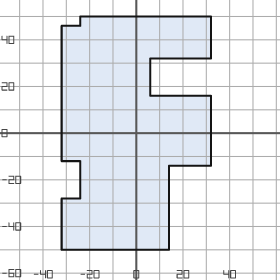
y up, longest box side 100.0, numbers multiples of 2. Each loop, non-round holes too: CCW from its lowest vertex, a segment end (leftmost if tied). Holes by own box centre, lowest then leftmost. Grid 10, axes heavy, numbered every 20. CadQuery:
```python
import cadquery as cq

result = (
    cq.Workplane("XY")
    .moveTo(-32.0, -50.0)
    .lineTo(14.0, -50.0)
    .lineTo(14.0, -14.0)
    .lineTo(32.0, -14.0)
    .lineTo(32.0, 16.0)
    .lineTo(6.0, 16.0)
    .lineTo(6.0, 32.0)
    .lineTo(32.0, 32.0)
    .lineTo(32.0, 50.0)
    .lineTo(-24.0, 50.0)
    .lineTo(-24.0, 46.0)
    .lineTo(-32.0, 46.0)
    .lineTo(-32.0, -12.0)
    .lineTo(-24.0, -12.0)
    .lineTo(-24.0, -28.0)
    .lineTo(-32.0, -28.0)
    .close()
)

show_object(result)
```